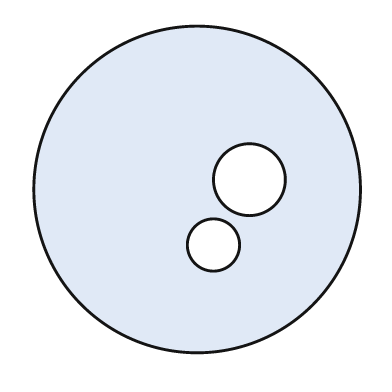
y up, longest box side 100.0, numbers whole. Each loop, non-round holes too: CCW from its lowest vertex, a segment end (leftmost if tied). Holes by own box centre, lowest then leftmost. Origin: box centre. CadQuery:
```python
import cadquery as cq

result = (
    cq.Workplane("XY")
    .moveTo(0.0, 0.0)
    .circle(50.0)
    .moveTo(5.0, -17.0)
    .circle(8.0)
    .moveTo(16.0, 3.0)
    .circle(11.0)
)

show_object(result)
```